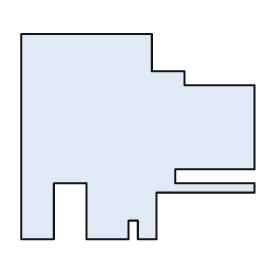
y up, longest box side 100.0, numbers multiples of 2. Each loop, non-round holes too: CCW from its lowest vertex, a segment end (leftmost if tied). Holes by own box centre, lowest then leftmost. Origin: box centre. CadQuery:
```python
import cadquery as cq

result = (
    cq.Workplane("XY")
    .moveTo(-50.0, -44.0)
    .lineTo(-36.0, -44.0)
    .lineTo(-36.0, -20.0)
    .lineTo(-22.0, -20.0)
    .lineTo(-22.0, -44.0)
    .lineTo(-4.0, -44.0)
    .lineTo(-4.0, -36.0)
    .lineTo(0.0, -36.0)
    .lineTo(0.0, -44.0)
    .lineTo(8.0, -44.0)
    .lineTo(8.0, -24.0)
    .lineTo(50.0, -24.0)
    .lineTo(50.0, -20.0)
    .lineTo(16.0, -20.0)
    .lineTo(16.0, -14.0)
    .lineTo(50.0, -14.0)
    .lineTo(50.0, 22.0)
    .lineTo(20.0, 22.0)
    .lineTo(20.0, 28.0)
    .lineTo(6.0, 28.0)
    .lineTo(6.0, 44.0)
    .lineTo(-50.0, 44.0)
    .close()
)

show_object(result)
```